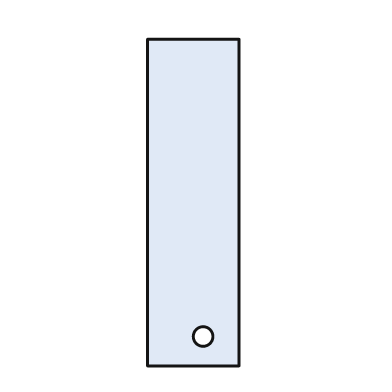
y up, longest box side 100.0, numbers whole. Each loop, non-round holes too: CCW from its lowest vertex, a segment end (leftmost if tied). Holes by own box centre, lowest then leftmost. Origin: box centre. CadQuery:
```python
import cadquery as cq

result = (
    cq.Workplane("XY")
    .moveTo(-14.0, -50.0)
    .lineTo(14.0, -50.0)
    .lineTo(14.0, 50.0)
    .lineTo(-14.0, 50.0)
    .close()
    .moveTo(3.0, -41.0)
    .circle(3.0)
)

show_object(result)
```